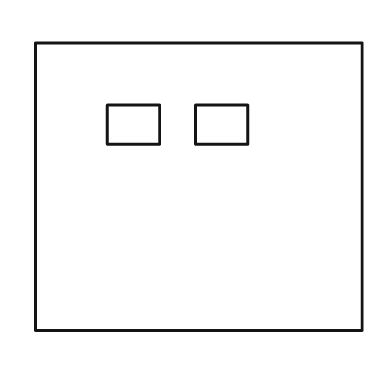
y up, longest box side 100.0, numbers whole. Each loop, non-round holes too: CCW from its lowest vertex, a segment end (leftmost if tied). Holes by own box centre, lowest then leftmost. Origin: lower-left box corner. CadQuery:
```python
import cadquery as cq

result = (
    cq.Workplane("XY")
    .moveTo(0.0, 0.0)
    .lineTo(100.0, 0.0)
    .lineTo(100.0, 88.0)
    .lineTo(0.0, 88.0)
    .close()
    .moveTo(22.0, 57.0)
    .lineTo(38.0, 57.0)
    .lineTo(38.0, 69.0)
    .lineTo(22.0, 69.0)
    .close()
    .moveTo(49.0, 57.0)
    .lineTo(65.0, 57.0)
    .lineTo(65.0, 69.0)
    .lineTo(49.0, 69.0)
    .close()
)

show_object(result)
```